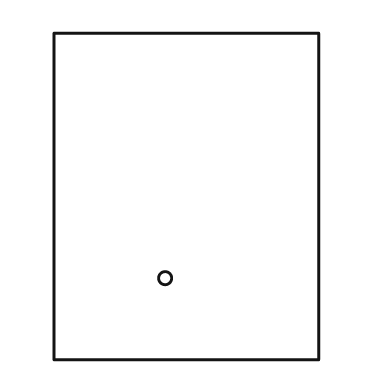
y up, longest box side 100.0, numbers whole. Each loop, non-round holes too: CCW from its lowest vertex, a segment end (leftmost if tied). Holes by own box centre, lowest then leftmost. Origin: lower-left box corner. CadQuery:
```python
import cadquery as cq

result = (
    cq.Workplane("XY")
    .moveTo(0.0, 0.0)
    .lineTo(81.0, 0.0)
    .lineTo(81.0, 100.0)
    .lineTo(0.0, 100.0)
    .close()
    .moveTo(34.0, 25.0)
    .circle(2.0)
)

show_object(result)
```